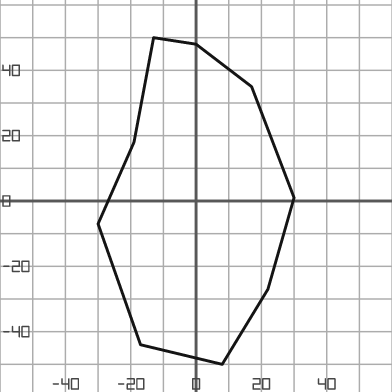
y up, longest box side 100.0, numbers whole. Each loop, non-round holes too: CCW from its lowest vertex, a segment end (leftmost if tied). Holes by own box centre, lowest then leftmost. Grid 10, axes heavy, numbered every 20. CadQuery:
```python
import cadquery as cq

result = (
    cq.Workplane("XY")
    .moveTo(8.0, -50.0)
    .lineTo(22.0, -27.0)
    .lineTo(30.0, 1.0)
    .lineTo(17.0, 35.0)
    .lineTo(0.0, 48.0)
    .lineTo(-13.0, 50.0)
    .lineTo(-19.0, 18.0)
    .lineTo(-30.0, -7.0)
    .lineTo(-17.0, -44.0)
    .close()
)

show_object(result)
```